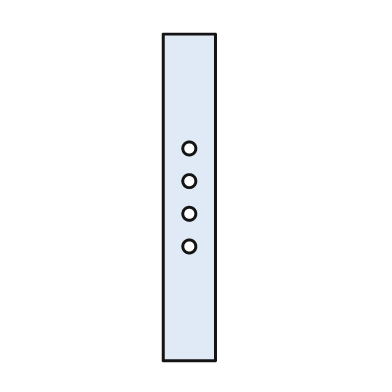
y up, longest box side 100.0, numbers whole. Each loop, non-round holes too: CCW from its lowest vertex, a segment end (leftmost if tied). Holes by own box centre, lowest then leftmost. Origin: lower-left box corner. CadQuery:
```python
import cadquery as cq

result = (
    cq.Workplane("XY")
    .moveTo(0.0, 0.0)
    .lineTo(16.0, 0.0)
    .lineTo(16.0, 100.0)
    .lineTo(0.0, 100.0)
    .close()
    .moveTo(8.0, 35.0)
    .circle(2.0)
    .moveTo(8.0, 45.0)
    .circle(2.0)
    .moveTo(8.0, 55.0)
    .circle(2.0)
    .moveTo(8.0, 65.0)
    .circle(2.0)
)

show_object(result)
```